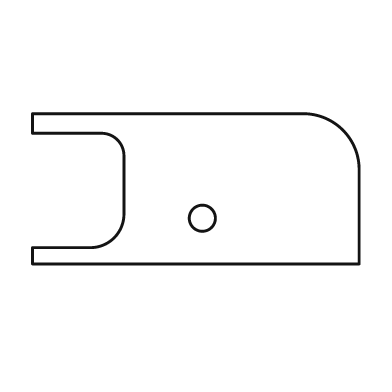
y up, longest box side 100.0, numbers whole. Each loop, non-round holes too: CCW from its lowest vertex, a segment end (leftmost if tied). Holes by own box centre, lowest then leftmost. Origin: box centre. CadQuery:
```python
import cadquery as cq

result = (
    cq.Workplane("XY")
    .moveTo(-50.0, -23.0)
    .lineTo(50.0, -23.0)
    .lineTo(50.0, 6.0)
    .threePointArc((45.0, 18.0), (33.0, 23.0))
    .lineTo(-50.0, 23.0)
    .lineTo(-50.0, 17.0)
    .lineTo(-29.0, 17.0)
    .threePointArc((-24.0, 15.0), (-22.0, 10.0))
    .lineTo(-22.0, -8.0)
    .threePointArc((-25.0, -15.0), (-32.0, -18.0))
    .lineTo(-50.0, -18.0)
    .close()
    .moveTo(2.0, -9.0)
    .circle(4.0)
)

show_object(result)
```